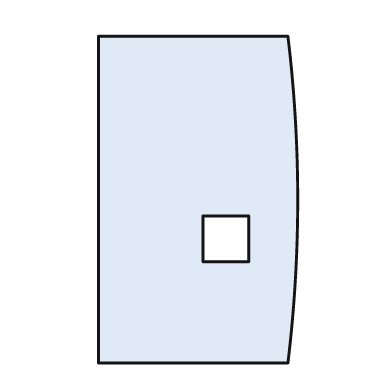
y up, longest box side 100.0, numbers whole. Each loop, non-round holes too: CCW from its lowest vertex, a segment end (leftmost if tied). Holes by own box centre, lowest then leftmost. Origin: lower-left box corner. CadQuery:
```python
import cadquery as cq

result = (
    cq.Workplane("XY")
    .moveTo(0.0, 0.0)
    .lineTo(58.0, 0.0)
    .threePointArc((61.0, 50.0), (58.0, 100.0))
    .lineTo(0.0, 100.0)
    .close()
    .moveTo(32.0, 31.0)
    .lineTo(46.0, 31.0)
    .lineTo(46.0, 45.0)
    .lineTo(32.0, 45.0)
    .close()
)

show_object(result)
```